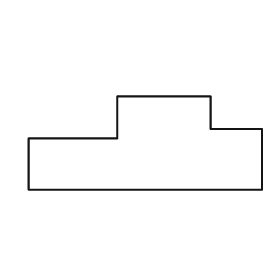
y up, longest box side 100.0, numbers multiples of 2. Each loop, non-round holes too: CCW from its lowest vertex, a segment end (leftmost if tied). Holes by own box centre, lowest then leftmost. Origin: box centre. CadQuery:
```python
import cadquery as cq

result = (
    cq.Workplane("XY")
    .moveTo(-50.0, -20.0)
    .lineTo(50.0, -20.0)
    .lineTo(50.0, 6.0)
    .lineTo(28.0, 6.0)
    .lineTo(28.0, 20.0)
    .lineTo(-12.0, 20.0)
    .lineTo(-12.0, 2.0)
    .lineTo(-50.0, 2.0)
    .close()
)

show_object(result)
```